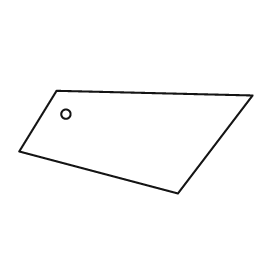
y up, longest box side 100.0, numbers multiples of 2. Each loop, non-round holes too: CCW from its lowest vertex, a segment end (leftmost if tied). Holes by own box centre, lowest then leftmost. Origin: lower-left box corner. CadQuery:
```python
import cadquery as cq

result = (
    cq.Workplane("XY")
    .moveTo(68.0, 0.0)
    .lineTo(100.0, 42.0)
    .lineTo(16.0, 44.0)
    .lineTo(0.0, 18.0)
    .close()
    .moveTo(20.0, 34.0)
    .circle(2.0)
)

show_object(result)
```